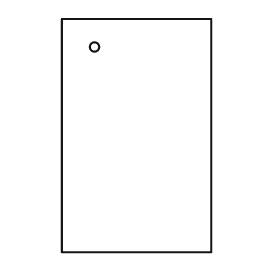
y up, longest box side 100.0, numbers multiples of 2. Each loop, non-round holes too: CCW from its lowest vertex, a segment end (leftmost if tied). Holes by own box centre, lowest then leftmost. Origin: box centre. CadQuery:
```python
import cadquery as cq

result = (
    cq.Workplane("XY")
    .moveTo(-32.0, -50.0)
    .lineTo(32.0, -50.0)
    .lineTo(32.0, 50.0)
    .lineTo(-32.0, 50.0)
    .close()
    .moveTo(-18.0, 38.0)
    .circle(2.0)
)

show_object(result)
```